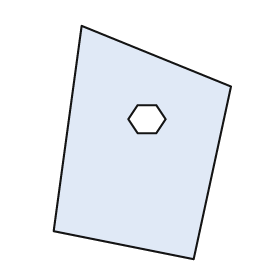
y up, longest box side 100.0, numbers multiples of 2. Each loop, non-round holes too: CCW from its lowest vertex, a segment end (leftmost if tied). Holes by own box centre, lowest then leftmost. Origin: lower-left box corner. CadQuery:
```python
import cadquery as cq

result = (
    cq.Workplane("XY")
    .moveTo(60.0, 0.0)
    .lineTo(76.0, 74.0)
    .lineTo(12.0, 100.0)
    .lineTo(0.0, 12.0)
    .close()
    .moveTo(36.0, 54.0)
    .lineTo(44.0, 54.0)
    .lineTo(48.0, 60.0)
    .lineTo(44.0, 66.0)
    .lineTo(36.0, 66.0)
    .lineTo(32.0, 60.0)
    .close()
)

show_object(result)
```